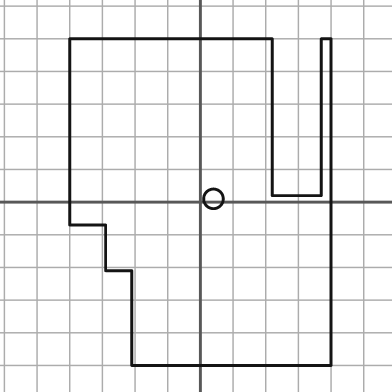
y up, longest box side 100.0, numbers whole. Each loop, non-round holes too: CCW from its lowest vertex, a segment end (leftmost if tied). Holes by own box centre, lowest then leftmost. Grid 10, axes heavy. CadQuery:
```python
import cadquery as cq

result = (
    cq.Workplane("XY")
    .moveTo(-21.0, -50.0)
    .lineTo(40.0, -50.0)
    .lineTo(40.0, 50.0)
    .lineTo(37.0, 50.0)
    .lineTo(37.0, 2.0)
    .lineTo(22.0, 2.0)
    .lineTo(22.0, 50.0)
    .lineTo(-40.0, 50.0)
    .lineTo(-40.0, -7.0)
    .lineTo(-29.0, -7.0)
    .lineTo(-29.0, -21.0)
    .lineTo(-21.0, -21.0)
    .close()
    .moveTo(4.0, 1.0)
    .circle(3.0)
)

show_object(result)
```